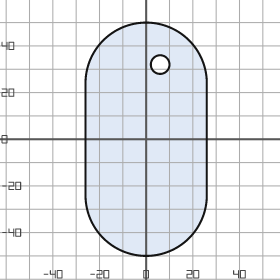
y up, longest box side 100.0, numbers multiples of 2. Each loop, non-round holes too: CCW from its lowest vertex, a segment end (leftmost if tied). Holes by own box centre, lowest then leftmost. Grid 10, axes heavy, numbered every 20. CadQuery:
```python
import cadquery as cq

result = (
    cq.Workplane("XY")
    .moveTo(-26.0, -24.0)
    .threePointArc((0.0, -50.0), (26.0, -24.0))
    .lineTo(26.0, 24.0)
    .threePointArc((0.0, 50.0), (-26.0, 24.0))
    .close()
    .moveTo(6.0, 32.0)
    .circle(4.0)
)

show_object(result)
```